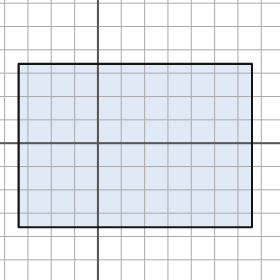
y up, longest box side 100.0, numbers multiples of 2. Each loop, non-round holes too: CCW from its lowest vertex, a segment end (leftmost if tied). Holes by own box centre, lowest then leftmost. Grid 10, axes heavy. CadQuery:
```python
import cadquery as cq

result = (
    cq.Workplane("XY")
    .moveTo(-34.0, -36.0)
    .lineTo(66.0, -36.0)
    .lineTo(66.0, 34.0)
    .lineTo(-34.0, 34.0)
    .close()
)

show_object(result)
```